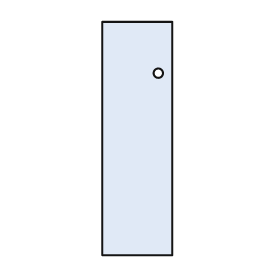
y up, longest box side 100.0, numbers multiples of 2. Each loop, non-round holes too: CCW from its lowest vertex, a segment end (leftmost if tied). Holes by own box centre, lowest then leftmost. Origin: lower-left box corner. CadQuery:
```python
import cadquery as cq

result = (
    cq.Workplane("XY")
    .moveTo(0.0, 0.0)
    .lineTo(30.0, 0.0)
    .lineTo(30.0, 100.0)
    .lineTo(0.0, 100.0)
    .close()
    .moveTo(24.0, 78.0)
    .circle(2.0)
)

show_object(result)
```